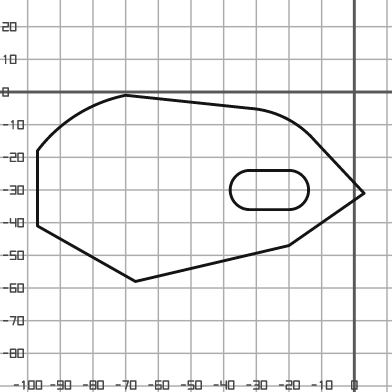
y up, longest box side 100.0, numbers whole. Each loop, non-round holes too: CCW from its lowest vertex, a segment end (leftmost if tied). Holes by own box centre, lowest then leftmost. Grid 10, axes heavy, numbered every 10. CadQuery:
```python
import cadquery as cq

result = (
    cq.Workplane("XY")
    .moveTo(-67.0, -58.0)
    .lineTo(-20.0, -47.0)
    .lineTo(3.0, -31.0)
    .lineTo(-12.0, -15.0)
    .threePointArc((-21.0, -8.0), (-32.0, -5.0))
    .lineTo(-70.0, -1.0)
    .threePointArc((-85.0, -7.0), (-97.0, -18.0))
    .lineTo(-97.0, -41.0)
    .close()
    .moveTo(-32.0, -36.0)
    .lineTo(-20.0, -36.0)
    .threePointArc((-14.0, -30.0), (-20.0, -24.0))
    .lineTo(-32.0, -24.0)
    .threePointArc((-38.0, -30.0), (-32.0, -36.0))
    .close()
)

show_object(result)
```